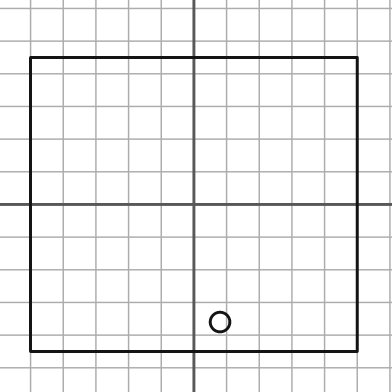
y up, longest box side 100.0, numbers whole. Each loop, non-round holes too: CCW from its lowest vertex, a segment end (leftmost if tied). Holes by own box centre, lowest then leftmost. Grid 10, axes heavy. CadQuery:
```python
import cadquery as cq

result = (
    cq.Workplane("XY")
    .moveTo(-50.0, -45.0)
    .lineTo(50.0, -45.0)
    .lineTo(50.0, 45.0)
    .lineTo(-50.0, 45.0)
    .close()
    .moveTo(8.0, -36.0)
    .circle(3.0)
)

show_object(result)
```